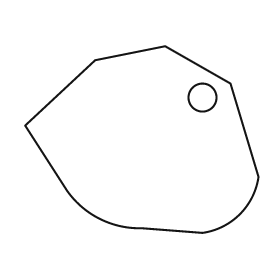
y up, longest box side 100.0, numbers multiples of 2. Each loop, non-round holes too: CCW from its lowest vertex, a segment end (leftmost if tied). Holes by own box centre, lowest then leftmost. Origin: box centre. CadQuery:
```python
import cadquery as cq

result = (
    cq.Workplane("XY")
    .moveTo(26.0, -40.0)
    .threePointArc((42.0, -32.0), (50.0, -16.0))
    .lineTo(38.0, 24.0)
    .lineTo(10.0, 40.0)
    .lineTo(-20.0, 34.0)
    .lineTo(-50.0, 6.0)
    .lineTo(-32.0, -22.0)
    .threePointArc((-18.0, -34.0), (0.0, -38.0))
    .close()
    .moveTo(26.0, 18.0)
    .circle(6.0)
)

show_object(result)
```